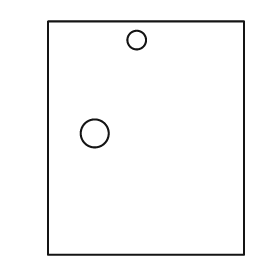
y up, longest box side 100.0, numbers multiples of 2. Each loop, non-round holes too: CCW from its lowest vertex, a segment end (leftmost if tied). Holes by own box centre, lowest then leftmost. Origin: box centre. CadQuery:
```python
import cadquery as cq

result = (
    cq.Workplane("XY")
    .moveTo(-42.0, -50.0)
    .lineTo(42.0, -50.0)
    .lineTo(42.0, 50.0)
    .lineTo(-42.0, 50.0)
    .close()
    .moveTo(-22.0, 2.0)
    .circle(6.0)
    .moveTo(-4.0, 42.0)
    .circle(4.0)
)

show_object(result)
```